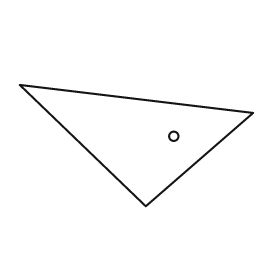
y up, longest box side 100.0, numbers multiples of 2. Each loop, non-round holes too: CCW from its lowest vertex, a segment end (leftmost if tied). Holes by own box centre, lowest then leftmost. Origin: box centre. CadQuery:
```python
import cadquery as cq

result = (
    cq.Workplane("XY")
    .moveTo(4.0, -26.0)
    .lineTo(50.0, 14.0)
    .lineTo(-50.0, 26.0)
    .close()
    .moveTo(16.0, 4.0)
    .circle(2.0)
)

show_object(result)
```